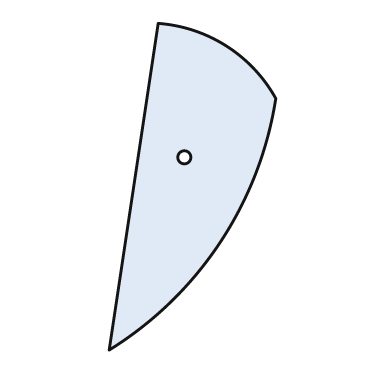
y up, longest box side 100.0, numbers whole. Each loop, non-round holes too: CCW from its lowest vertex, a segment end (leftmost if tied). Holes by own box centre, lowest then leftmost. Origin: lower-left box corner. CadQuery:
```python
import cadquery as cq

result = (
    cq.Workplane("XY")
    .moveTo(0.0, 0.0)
    .threePointArc((34.0, 33.0), (51.0, 77.0))
    .threePointArc((36.0, 93.0), (15.0, 100.0))
    .close()
    .moveTo(23.0, 59.0)
    .circle(2.0)
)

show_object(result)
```